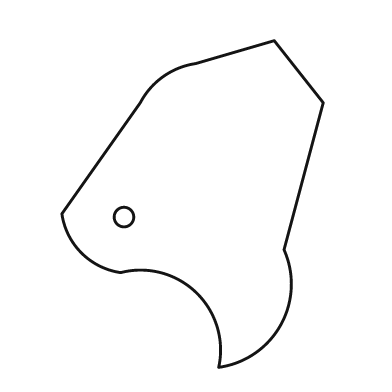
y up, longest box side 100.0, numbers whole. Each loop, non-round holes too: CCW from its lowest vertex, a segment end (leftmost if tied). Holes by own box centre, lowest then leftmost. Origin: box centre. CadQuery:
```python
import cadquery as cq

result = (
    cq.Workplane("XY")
    .moveTo(8.0, -50.0)
    .threePointArc((27.0, -37.0), (28.0, -14.0))
    .lineTo(40.0, 31.0)
    .lineTo(25.0, 50.0)
    .lineTo(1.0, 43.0)
    .threePointArc((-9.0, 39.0), (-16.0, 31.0))
    .lineTo(-40.0, -3.0)
    .threePointArc((-34.0, -15.0), (-22.0, -21.0))
    .threePointArc((1.0, -27.0), (8.0, -50.0))
    .close()
    .moveTo(-21.0, -4.0)
    .circle(3.0)
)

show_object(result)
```